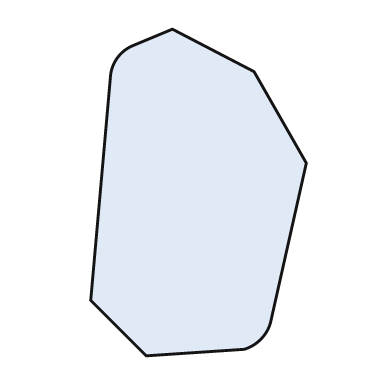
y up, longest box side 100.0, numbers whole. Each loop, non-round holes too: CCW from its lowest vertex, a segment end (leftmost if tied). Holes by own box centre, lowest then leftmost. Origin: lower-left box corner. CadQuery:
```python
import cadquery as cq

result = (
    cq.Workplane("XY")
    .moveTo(17.0, 0.0)
    .lineTo(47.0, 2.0)
    .threePointArc((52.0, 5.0), (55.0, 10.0))
    .lineTo(66.0, 59.0)
    .lineTo(50.0, 87.0)
    .lineTo(25.0, 100.0)
    .lineTo(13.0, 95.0)
    .threePointArc((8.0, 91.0), (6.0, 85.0))
    .lineTo(0.0, 17.0)
    .close()
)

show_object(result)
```